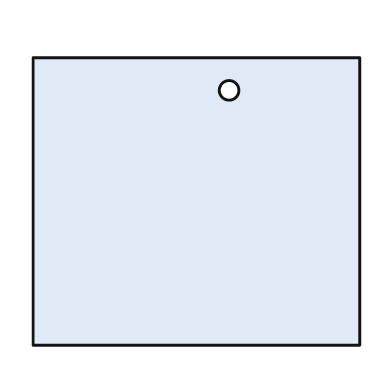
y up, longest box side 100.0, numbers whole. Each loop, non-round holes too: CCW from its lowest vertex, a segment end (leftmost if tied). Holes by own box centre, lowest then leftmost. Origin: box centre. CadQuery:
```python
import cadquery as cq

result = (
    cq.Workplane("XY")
    .moveTo(-50.0, -44.0)
    .lineTo(50.0, -44.0)
    .lineTo(50.0, 44.0)
    .lineTo(-50.0, 44.0)
    .close()
    .moveTo(10.0, 34.0)
    .circle(3.0)
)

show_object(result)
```